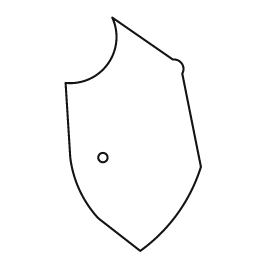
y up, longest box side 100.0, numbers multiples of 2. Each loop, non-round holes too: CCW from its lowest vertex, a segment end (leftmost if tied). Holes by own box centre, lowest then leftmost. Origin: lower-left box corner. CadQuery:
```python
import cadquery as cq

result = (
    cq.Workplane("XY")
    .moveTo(32.0, 0.0)
    .threePointArc((48.0, 16.0), (58.0, 36.0))
    .lineTo(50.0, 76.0)
    .threePointArc((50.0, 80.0), (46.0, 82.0))
    .lineTo(20.0, 100.0)
    .threePointArc((18.0, 80.0), (0.0, 72.0))
    .lineTo(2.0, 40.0)
    .threePointArc((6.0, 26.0), (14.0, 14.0))
    .close()
    .moveTo(16.0, 40.0)
    .circle(2.0)
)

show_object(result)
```